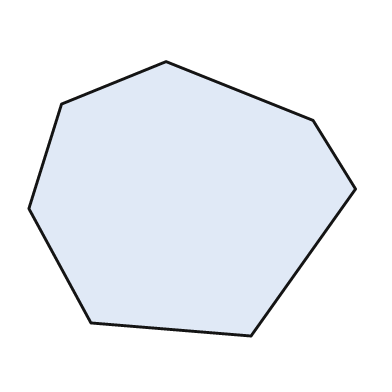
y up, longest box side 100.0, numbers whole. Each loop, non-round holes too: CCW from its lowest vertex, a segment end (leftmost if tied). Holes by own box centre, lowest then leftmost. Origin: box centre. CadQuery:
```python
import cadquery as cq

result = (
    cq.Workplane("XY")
    .moveTo(18.0, -42.0)
    .lineTo(50.0, 3.0)
    .lineTo(37.0, 24.0)
    .lineTo(-8.0, 42.0)
    .lineTo(-40.0, 29.0)
    .lineTo(-50.0, -3.0)
    .lineTo(-31.0, -38.0)
    .close()
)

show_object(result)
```